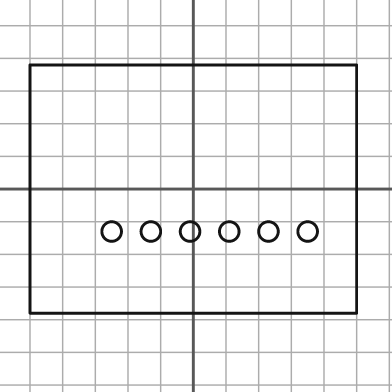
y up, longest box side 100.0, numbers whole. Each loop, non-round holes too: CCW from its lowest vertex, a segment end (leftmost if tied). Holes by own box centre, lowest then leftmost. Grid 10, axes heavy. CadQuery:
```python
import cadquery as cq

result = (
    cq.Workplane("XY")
    .moveTo(-50.0, -38.0)
    .lineTo(50.0, -38.0)
    .lineTo(50.0, 38.0)
    .lineTo(-50.0, 38.0)
    .close()
    .moveTo(-25.0, -13.0)
    .circle(3.0)
    .moveTo(-13.0, -13.0)
    .circle(3.0)
    .moveTo(-1.0, -13.0)
    .circle(3.0)
    .moveTo(11.0, -13.0)
    .circle(3.0)
    .moveTo(23.0, -13.0)
    .circle(3.0)
    .moveTo(35.0, -13.0)
    .circle(3.0)
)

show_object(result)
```